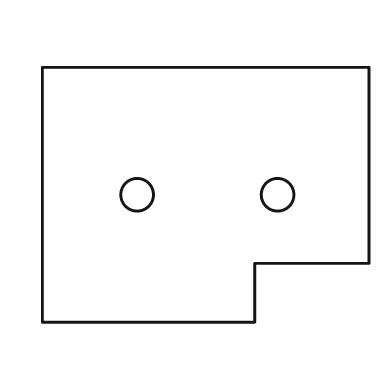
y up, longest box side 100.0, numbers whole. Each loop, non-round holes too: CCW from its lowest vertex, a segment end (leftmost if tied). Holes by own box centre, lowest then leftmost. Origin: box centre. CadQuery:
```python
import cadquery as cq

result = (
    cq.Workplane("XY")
    .moveTo(-50.0, -39.0)
    .lineTo(15.0, -39.0)
    .lineTo(15.0, -21.0)
    .lineTo(50.0, -21.0)
    .lineTo(50.0, 39.0)
    .lineTo(-50.0, 39.0)
    .close()
    .moveTo(-21.0, 0.0)
    .circle(5.0)
    .moveTo(22.0, 0.0)
    .circle(5.0)
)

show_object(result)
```